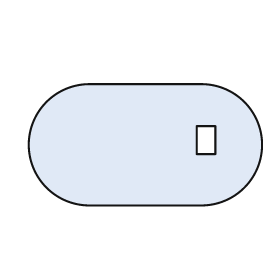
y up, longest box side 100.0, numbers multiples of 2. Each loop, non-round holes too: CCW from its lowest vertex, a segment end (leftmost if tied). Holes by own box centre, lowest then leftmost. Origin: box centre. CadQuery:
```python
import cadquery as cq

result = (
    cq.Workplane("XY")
    .moveTo(-24.0, -26.0)
    .lineTo(24.0, -26.0)
    .threePointArc((50.0, 0.0), (24.0, 26.0))
    .lineTo(-24.0, 26.0)
    .threePointArc((-50.0, 0.0), (-24.0, -26.0))
    .close()
    .moveTo(22.0, -4.0)
    .lineTo(30.0, -4.0)
    .lineTo(30.0, 8.0)
    .lineTo(22.0, 8.0)
    .close()
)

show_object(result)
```